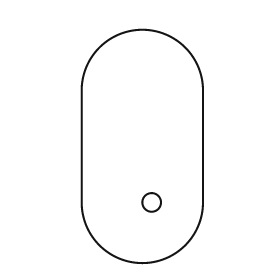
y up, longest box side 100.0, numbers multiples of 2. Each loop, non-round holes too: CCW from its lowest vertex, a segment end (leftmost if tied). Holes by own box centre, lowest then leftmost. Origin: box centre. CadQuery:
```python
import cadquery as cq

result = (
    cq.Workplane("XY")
    .moveTo(-26.0, -24.0)
    .threePointArc((0.0, -50.0), (26.0, -24.0))
    .lineTo(26.0, 24.0)
    .threePointArc((0.0, 50.0), (-26.0, 24.0))
    .close()
    .moveTo(4.0, -24.0)
    .circle(4.0)
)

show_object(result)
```